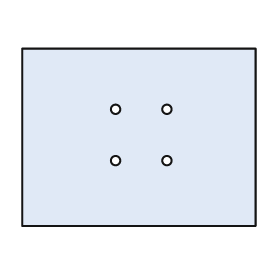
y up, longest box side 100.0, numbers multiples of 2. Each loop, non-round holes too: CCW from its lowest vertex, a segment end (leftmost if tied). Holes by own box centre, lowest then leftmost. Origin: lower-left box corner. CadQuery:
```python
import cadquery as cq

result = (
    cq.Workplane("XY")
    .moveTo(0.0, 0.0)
    .lineTo(100.0, 0.0)
    .lineTo(100.0, 76.0)
    .lineTo(0.0, 76.0)
    .close()
    .moveTo(40.0, 28.0)
    .circle(2.0)
    .moveTo(62.0, 28.0)
    .circle(2.0)
    .moveTo(40.0, 50.0)
    .circle(2.0)
    .moveTo(62.0, 50.0)
    .circle(2.0)
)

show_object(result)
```